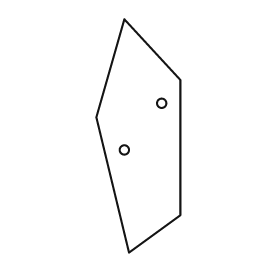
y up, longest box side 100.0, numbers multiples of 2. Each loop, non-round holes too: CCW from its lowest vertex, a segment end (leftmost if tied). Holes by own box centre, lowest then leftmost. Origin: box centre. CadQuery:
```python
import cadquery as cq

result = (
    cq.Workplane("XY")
    .moveTo(-4.0, -50.0)
    .lineTo(18.0, -34.0)
    .lineTo(18.0, 24.0)
    .lineTo(-6.0, 50.0)
    .lineTo(-18.0, 8.0)
    .close()
    .moveTo(-6.0, -6.0)
    .circle(2.0)
    .moveTo(10.0, 14.0)
    .circle(2.0)
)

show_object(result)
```